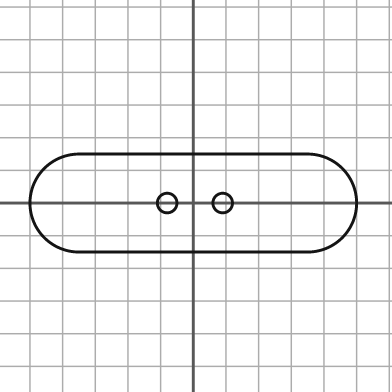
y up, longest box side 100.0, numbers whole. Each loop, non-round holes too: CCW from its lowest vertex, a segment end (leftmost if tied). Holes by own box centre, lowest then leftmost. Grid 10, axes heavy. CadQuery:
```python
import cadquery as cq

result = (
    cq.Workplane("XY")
    .moveTo(-35.0, -15.0)
    .lineTo(35.0, -15.0)
    .threePointArc((50.0, 0.0), (35.0, 15.0))
    .lineTo(-35.0, 15.0)
    .threePointArc((-50.0, 0.0), (-35.0, -15.0))
    .close()
    .moveTo(-8.0, 0.0)
    .circle(3.0)
    .moveTo(9.0, 0.0)
    .circle(3.0)
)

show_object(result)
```